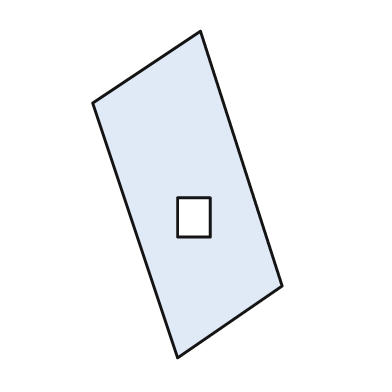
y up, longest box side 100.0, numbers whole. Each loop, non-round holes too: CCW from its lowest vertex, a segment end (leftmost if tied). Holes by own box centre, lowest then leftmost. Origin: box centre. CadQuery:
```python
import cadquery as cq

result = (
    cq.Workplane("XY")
    .moveTo(-3.0, -50.0)
    .lineTo(29.0, -28.0)
    .lineTo(4.0, 50.0)
    .lineTo(-29.0, 28.0)
    .close()
    .moveTo(-3.0, -13.0)
    .lineTo(7.0, -13.0)
    .lineTo(7.0, -1.0)
    .lineTo(-3.0, -1.0)
    .close()
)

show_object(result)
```